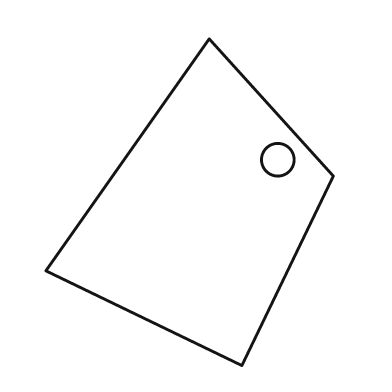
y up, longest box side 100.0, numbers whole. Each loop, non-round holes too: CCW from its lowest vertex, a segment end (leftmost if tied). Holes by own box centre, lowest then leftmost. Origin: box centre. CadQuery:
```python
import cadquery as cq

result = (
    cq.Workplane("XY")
    .moveTo(16.0, -50.0)
    .lineTo(44.0, 8.0)
    .lineTo(6.0, 50.0)
    .lineTo(-44.0, -21.0)
    .close()
    .moveTo(27.0, 13.0)
    .circle(5.0)
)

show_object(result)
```